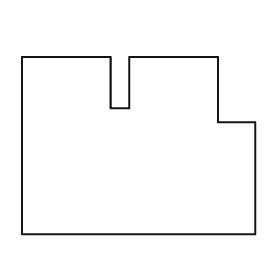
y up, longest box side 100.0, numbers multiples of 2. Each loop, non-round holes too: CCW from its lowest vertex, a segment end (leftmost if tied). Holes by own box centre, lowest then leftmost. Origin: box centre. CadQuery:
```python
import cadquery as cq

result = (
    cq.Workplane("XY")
    .moveTo(-50.0, -38.0)
    .lineTo(50.0, -38.0)
    .lineTo(50.0, 10.0)
    .lineTo(34.0, 10.0)
    .lineTo(34.0, 38.0)
    .lineTo(-4.0, 38.0)
    .lineTo(-4.0, 16.0)
    .lineTo(-12.0, 16.0)
    .lineTo(-12.0, 38.0)
    .lineTo(-50.0, 38.0)
    .close()
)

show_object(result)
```